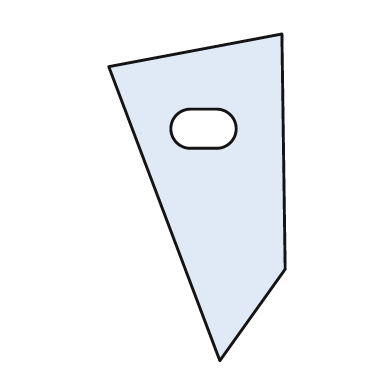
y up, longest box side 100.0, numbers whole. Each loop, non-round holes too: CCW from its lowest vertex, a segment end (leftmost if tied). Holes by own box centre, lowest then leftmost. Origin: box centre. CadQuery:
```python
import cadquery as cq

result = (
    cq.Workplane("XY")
    .moveTo(7.0, -50.0)
    .lineTo(27.0, -22.0)
    .lineTo(26.0, 50.0)
    .lineTo(-27.0, 40.0)
    .close()
    .moveTo(-2.0, 15.0)
    .lineTo(6.0, 15.0)
    .threePointArc((12.0, 21.0), (6.0, 27.0))
    .lineTo(-2.0, 27.0)
    .threePointArc((-8.0, 21.0), (-2.0, 15.0))
    .close()
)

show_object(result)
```